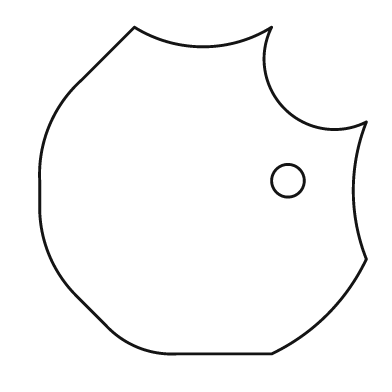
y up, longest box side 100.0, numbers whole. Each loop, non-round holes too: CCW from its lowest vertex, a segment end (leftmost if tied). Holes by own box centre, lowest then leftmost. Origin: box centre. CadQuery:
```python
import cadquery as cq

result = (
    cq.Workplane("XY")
    .moveTo(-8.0, -50.0)
    .lineTo(21.0, -50.0)
    .threePointArc((38.0, -38.0), (50.0, -21.0))
    .threePointArc((46.0, 0.0), (50.0, 21.0))
    .threePointArc((25.0, 25.0), (21.0, 50.0))
    .threePointArc((0.0, 44.0), (-21.0, 50.0))
    .lineTo(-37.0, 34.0)
    .threePointArc((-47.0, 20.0), (-50.0, 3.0))
    .lineTo(-50.0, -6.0)
    .threePointArc((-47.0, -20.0), (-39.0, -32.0))
    .lineTo(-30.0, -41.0)
    .threePointArc((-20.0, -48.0), (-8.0, -50.0))
    .close()
    .moveTo(26.0, 3.0)
    .circle(5.0)
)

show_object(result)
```